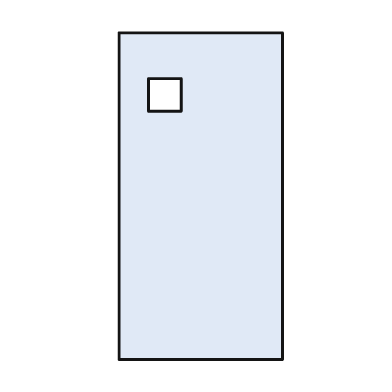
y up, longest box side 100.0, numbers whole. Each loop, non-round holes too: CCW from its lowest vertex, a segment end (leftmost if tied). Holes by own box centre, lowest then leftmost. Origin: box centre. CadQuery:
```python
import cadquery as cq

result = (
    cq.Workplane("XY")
    .moveTo(-25.0, -50.0)
    .lineTo(25.0, -50.0)
    .lineTo(25.0, 50.0)
    .lineTo(-25.0, 50.0)
    .close()
    .moveTo(-16.0, 26.0)
    .lineTo(-6.0, 26.0)
    .lineTo(-6.0, 36.0)
    .lineTo(-16.0, 36.0)
    .close()
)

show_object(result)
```